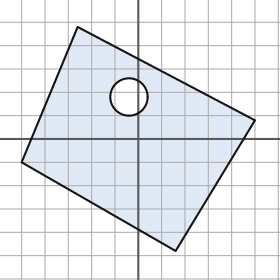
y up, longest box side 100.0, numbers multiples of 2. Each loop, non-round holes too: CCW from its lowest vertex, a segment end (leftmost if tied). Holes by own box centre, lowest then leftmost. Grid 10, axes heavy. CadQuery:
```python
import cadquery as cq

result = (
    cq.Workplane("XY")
    .moveTo(16.0, -48.0)
    .lineTo(50.0, 8.0)
    .lineTo(-26.0, 48.0)
    .lineTo(-50.0, -10.0)
    .close()
    .moveTo(-4.0, 18.0)
    .circle(8.0)
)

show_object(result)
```